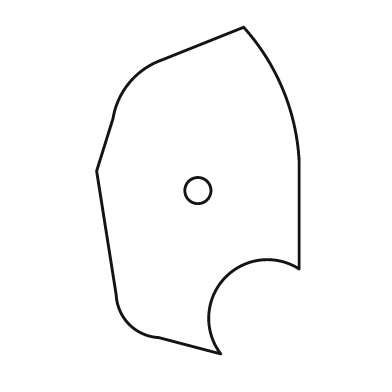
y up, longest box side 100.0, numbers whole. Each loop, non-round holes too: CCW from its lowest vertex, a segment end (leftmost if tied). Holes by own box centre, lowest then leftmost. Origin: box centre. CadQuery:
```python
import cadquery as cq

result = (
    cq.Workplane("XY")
    .moveTo(7.0, -50.0)
    .threePointArc((8.0, -27.0), (31.0, -24.0))
    .lineTo(31.0, 9.0)
    .threePointArc((26.0, 31.0), (14.0, 50.0))
    .lineTo(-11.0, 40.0)
    .threePointArc((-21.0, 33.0), (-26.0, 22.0))
    .lineTo(-31.0, 6.0)
    .lineTo(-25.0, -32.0)
    .threePointArc((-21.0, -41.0), (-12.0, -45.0))
    .close()
    .moveTo(0.0, 0.0)
    .circle(4.0)
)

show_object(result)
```